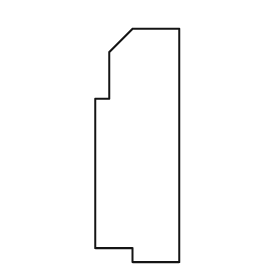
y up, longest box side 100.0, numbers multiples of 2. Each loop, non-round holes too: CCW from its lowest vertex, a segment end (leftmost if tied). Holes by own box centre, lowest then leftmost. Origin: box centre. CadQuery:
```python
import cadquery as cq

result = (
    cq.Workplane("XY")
    .moveTo(-2.0, -50.0)
    .lineTo(18.0, -50.0)
    .lineTo(18.0, 50.0)
    .lineTo(-2.0, 50.0)
    .lineTo(-12.0, 40.0)
    .lineTo(-12.0, 20.0)
    .lineTo(-18.0, 20.0)
    .lineTo(-18.0, -44.0)
    .lineTo(-2.0, -44.0)
    .close()
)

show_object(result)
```